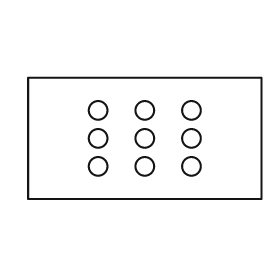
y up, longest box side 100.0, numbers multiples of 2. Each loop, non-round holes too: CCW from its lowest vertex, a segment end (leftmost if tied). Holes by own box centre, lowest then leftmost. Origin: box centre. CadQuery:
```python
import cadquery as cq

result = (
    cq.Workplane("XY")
    .moveTo(-50.0, -26.0)
    .lineTo(50.0, -26.0)
    .lineTo(50.0, 26.0)
    .lineTo(-50.0, 26.0)
    .close()
    .moveTo(-20.0, -12.0)
    .circle(4.0)
    .moveTo(0.0, -12.0)
    .circle(4.0)
    .moveTo(20.0, -12.0)
    .circle(4.0)
    .moveTo(-20.0, 0.0)
    .circle(4.0)
    .moveTo(0.0, 0.0)
    .circle(4.0)
    .moveTo(20.0, 0.0)
    .circle(4.0)
    .moveTo(-20.0, 12.0)
    .circle(4.0)
    .moveTo(0.0, 12.0)
    .circle(4.0)
    .moveTo(20.0, 12.0)
    .circle(4.0)
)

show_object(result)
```